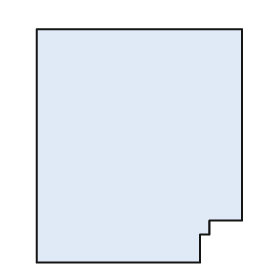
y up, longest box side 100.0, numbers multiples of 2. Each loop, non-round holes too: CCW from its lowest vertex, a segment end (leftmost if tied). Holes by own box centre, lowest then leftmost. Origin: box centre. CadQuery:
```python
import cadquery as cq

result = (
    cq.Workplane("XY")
    .moveTo(-44.0, -50.0)
    .lineTo(26.0, -50.0)
    .lineTo(26.0, -38.0)
    .lineTo(30.0, -38.0)
    .lineTo(30.0, -32.0)
    .lineTo(44.0, -32.0)
    .lineTo(44.0, 50.0)
    .lineTo(-44.0, 50.0)
    .close()
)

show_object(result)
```